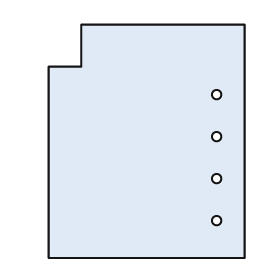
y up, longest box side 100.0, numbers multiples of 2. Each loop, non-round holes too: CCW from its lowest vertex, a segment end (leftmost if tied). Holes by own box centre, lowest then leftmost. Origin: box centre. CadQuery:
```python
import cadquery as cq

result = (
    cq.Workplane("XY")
    .moveTo(-42.0, -50.0)
    .lineTo(42.0, -50.0)
    .lineTo(42.0, 50.0)
    .lineTo(-28.0, 50.0)
    .lineTo(-28.0, 32.0)
    .lineTo(-42.0, 32.0)
    .close()
    .moveTo(30.0, -34.0)
    .circle(2.0)
    .moveTo(30.0, -16.0)
    .circle(2.0)
    .moveTo(30.0, 2.0)
    .circle(2.0)
    .moveTo(30.0, 20.0)
    .circle(2.0)
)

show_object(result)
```